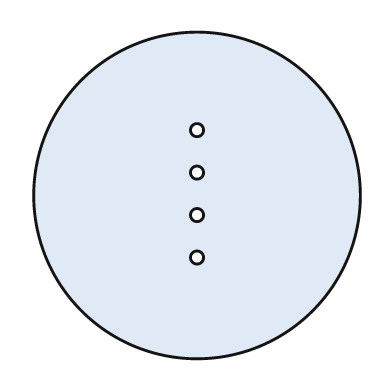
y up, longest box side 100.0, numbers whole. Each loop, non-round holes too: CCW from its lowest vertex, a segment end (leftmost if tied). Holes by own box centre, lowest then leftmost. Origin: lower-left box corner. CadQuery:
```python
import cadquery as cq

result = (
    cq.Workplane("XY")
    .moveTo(50.0, 50.0)
    .circle(50.0)
    .moveTo(50.0, 31.0)
    .circle(2.0)
    .moveTo(50.0, 44.0)
    .circle(2.0)
    .moveTo(50.0, 57.0)
    .circle(2.0)
    .moveTo(50.0, 70.0)
    .circle(2.0)
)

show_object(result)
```